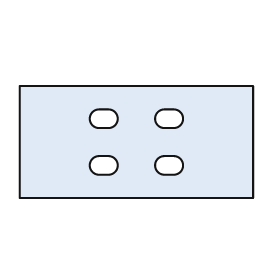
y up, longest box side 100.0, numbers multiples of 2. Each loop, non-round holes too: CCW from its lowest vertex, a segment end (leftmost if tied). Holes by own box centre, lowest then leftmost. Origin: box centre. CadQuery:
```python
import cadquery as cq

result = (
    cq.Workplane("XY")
    .moveTo(-50.0, -24.0)
    .lineTo(50.0, -24.0)
    .lineTo(50.0, 24.0)
    .lineTo(-50.0, 24.0)
    .close()
    .moveTo(-16.0, -14.0)
    .lineTo(-12.0, -14.0)
    .threePointArc((-8.0, -10.0), (-12.0, -6.0))
    .lineTo(-16.0, -6.0)
    .threePointArc((-20.0, -10.0), (-16.0, -14.0))
    .close()
    .moveTo(12.0, -14.0)
    .lineTo(16.0, -14.0)
    .threePointArc((20.0, -10.0), (16.0, -6.0))
    .lineTo(12.0, -6.0)
    .threePointArc((8.0, -10.0), (12.0, -14.0))
    .close()
    .moveTo(-16.0, 6.0)
    .lineTo(-12.0, 6.0)
    .threePointArc((-8.0, 10.0), (-12.0, 14.0))
    .lineTo(-16.0, 14.0)
    .threePointArc((-20.0, 10.0), (-16.0, 6.0))
    .close()
    .moveTo(12.0, 6.0)
    .lineTo(16.0, 6.0)
    .threePointArc((20.0, 10.0), (16.0, 14.0))
    .lineTo(12.0, 14.0)
    .threePointArc((8.0, 10.0), (12.0, 6.0))
    .close()
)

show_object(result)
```